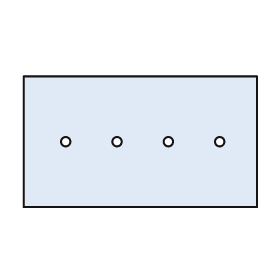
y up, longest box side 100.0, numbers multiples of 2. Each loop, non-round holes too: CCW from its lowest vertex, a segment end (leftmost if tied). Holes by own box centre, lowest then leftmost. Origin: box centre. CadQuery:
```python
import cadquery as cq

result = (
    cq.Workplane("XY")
    .moveTo(-50.0, -28.0)
    .lineTo(50.0, -28.0)
    .lineTo(50.0, 28.0)
    .lineTo(-50.0, 28.0)
    .close()
    .moveTo(-32.0, 0.0)
    .circle(2.0)
    .moveTo(-10.0, 0.0)
    .circle(2.0)
    .moveTo(12.0, 0.0)
    .circle(2.0)
    .moveTo(34.0, 0.0)
    .circle(2.0)
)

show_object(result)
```